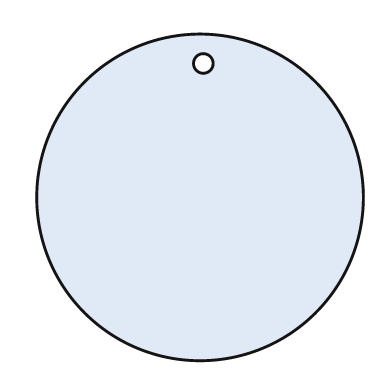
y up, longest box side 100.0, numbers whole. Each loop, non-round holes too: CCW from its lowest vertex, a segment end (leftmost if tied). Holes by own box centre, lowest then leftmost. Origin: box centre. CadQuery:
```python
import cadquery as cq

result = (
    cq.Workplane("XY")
    .moveTo(0.0, 0.0)
    .circle(50.0)
    .moveTo(1.0, 41.0)
    .circle(3.0)
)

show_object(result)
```